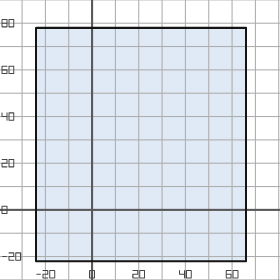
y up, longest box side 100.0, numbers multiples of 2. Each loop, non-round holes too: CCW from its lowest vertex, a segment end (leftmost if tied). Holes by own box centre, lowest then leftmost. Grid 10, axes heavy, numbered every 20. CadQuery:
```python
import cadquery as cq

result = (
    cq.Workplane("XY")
    .moveTo(-24.0, -22.0)
    .lineTo(66.0, -22.0)
    .lineTo(66.0, 78.0)
    .lineTo(-24.0, 78.0)
    .close()
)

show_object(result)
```